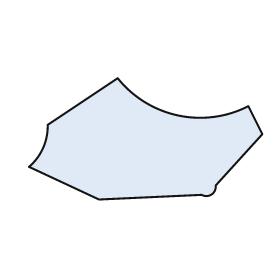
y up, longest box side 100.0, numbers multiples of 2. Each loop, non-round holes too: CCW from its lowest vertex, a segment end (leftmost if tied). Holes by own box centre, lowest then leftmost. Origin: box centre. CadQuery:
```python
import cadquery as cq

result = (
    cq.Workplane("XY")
    .moveTo(-20.0, -26.0)
    .lineTo(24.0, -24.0)
    .threePointArc((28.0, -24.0), (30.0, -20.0))
    .lineTo(50.0, 2.0)
    .lineTo(44.0, 14.0)
    .threePointArc((14.0, 10.0), (-12.0, 26.0))
    .lineTo(-42.0, 6.0)
    .threePointArc((-44.0, -4.0), (-50.0, -12.0))
    .close()
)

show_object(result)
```